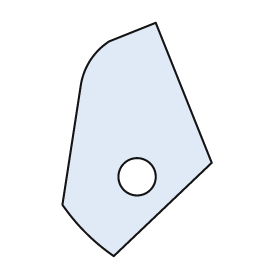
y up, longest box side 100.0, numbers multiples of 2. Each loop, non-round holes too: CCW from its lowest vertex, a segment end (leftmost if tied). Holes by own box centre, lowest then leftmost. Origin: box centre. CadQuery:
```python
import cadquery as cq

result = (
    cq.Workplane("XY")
    .moveTo(-10.0, -50.0)
    .lineTo(32.0, -10.0)
    .lineTo(8.0, 50.0)
    .lineTo(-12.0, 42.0)
    .threePointArc((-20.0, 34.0), (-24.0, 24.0))
    .lineTo(-32.0, -28.0)
    .threePointArc((-22.0, -40.0), (-10.0, -50.0))
    .close()
    .moveTo(0.0, -16.0)
    .circle(8.0)
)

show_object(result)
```